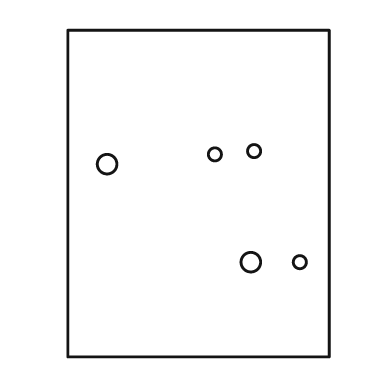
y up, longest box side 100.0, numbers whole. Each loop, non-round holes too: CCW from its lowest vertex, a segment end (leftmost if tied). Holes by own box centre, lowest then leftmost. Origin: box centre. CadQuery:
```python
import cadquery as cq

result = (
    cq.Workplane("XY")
    .moveTo(-40.0, -50.0)
    .lineTo(40.0, -50.0)
    .lineTo(40.0, 50.0)
    .lineTo(-40.0, 50.0)
    .close()
    .moveTo(16.0, -21.0)
    .circle(3.0)
    .moveTo(31.0, -21.0)
    .circle(2.0)
    .moveTo(-28.0, 9.0)
    .circle(3.0)
    .moveTo(5.0, 12.0)
    .circle(2.0)
    .moveTo(17.0, 13.0)
    .circle(2.0)
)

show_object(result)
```